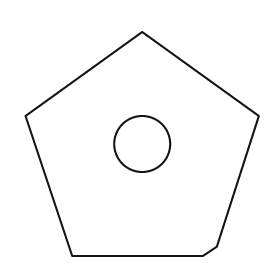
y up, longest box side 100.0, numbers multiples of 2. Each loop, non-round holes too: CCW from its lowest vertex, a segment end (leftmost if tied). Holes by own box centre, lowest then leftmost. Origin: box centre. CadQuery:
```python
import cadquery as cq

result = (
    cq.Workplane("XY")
    .moveTo(-30.0, -48.0)
    .lineTo(26.0, -48.0)
    .lineTo(32.0, -44.0)
    .lineTo(50.0, 12.0)
    .lineTo(0.0, 48.0)
    .lineTo(-50.0, 12.0)
    .close()
    .moveTo(0.0, 0.0)
    .circle(12.0)
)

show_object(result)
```